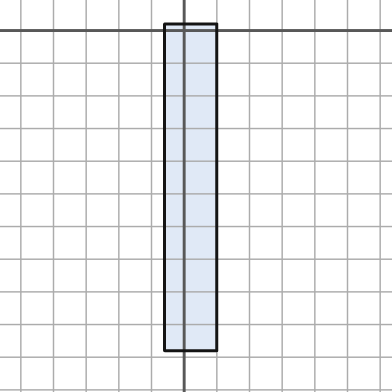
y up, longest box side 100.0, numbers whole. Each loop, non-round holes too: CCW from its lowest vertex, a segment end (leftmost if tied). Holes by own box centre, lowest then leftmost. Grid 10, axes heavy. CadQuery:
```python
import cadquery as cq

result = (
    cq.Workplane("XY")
    .moveTo(-6.0, -98.0)
    .lineTo(10.0, -98.0)
    .lineTo(10.0, 2.0)
    .lineTo(-6.0, 2.0)
    .close()
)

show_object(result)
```